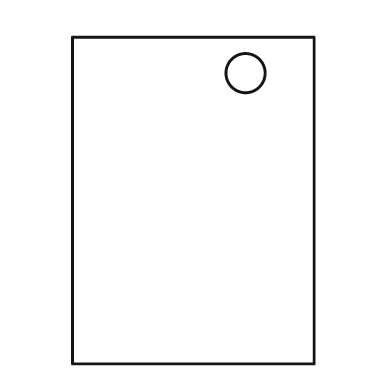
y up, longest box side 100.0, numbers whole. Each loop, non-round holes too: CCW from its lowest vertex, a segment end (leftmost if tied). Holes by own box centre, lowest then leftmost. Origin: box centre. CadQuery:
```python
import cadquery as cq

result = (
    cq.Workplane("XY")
    .moveTo(-37.0, -50.0)
    .lineTo(37.0, -50.0)
    .lineTo(37.0, 50.0)
    .lineTo(-37.0, 50.0)
    .close()
    .moveTo(16.0, 39.0)
    .circle(6.0)
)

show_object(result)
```